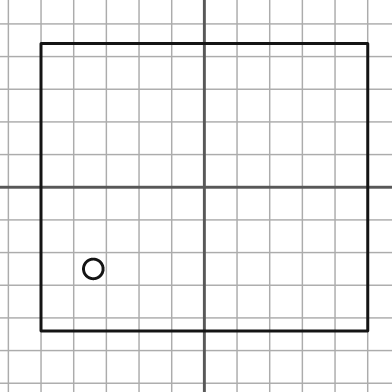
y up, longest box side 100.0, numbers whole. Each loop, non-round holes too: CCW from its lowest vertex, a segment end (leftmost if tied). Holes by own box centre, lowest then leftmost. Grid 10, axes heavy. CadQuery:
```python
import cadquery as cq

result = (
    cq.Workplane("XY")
    .moveTo(-50.0, -44.0)
    .lineTo(50.0, -44.0)
    .lineTo(50.0, 44.0)
    .lineTo(-50.0, 44.0)
    .close()
    .moveTo(-34.0, -25.0)
    .circle(3.0)
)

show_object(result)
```